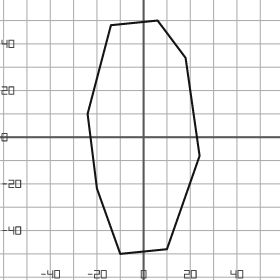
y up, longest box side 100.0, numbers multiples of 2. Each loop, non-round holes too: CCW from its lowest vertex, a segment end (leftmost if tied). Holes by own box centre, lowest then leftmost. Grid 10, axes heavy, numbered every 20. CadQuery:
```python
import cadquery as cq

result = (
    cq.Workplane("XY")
    .moveTo(-10.0, -50.0)
    .lineTo(10.0, -48.0)
    .lineTo(24.0, -8.0)
    .lineTo(18.0, 34.0)
    .lineTo(6.0, 50.0)
    .lineTo(-14.0, 48.0)
    .lineTo(-24.0, 10.0)
    .lineTo(-20.0, -22.0)
    .close()
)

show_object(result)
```